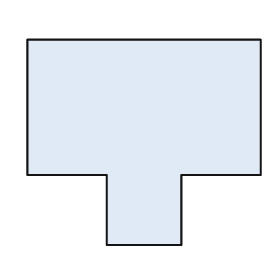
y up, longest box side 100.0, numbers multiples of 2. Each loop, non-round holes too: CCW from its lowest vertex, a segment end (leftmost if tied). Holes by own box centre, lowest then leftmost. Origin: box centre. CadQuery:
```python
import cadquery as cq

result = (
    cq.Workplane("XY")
    .moveTo(-16.0, -44.0)
    .lineTo(16.0, -44.0)
    .lineTo(16.0, -14.0)
    .lineTo(50.0, -14.0)
    .lineTo(50.0, 44.0)
    .lineTo(-50.0, 44.0)
    .lineTo(-50.0, -14.0)
    .lineTo(-16.0, -14.0)
    .close()
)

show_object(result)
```